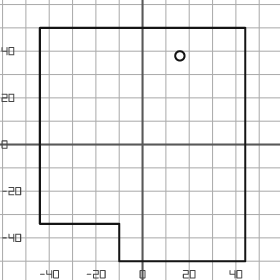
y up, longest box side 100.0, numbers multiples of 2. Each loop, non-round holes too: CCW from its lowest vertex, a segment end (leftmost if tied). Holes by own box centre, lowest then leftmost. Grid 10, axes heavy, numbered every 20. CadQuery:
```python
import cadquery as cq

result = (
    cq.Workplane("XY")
    .moveTo(-10.0, -50.0)
    .lineTo(44.0, -50.0)
    .lineTo(44.0, 50.0)
    .lineTo(-44.0, 50.0)
    .lineTo(-44.0, -34.0)
    .lineTo(-10.0, -34.0)
    .close()
    .moveTo(16.0, 38.0)
    .circle(2.0)
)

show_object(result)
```